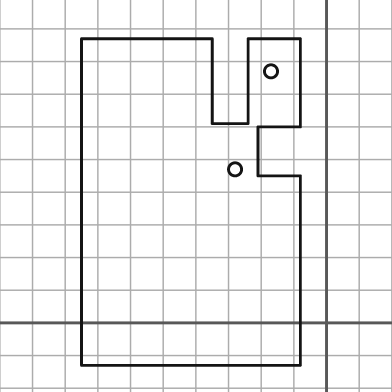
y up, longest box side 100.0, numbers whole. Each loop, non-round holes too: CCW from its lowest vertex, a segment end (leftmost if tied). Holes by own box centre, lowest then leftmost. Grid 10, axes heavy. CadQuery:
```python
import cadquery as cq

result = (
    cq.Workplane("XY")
    .moveTo(-75.0, -13.0)
    .lineTo(-8.0, -13.0)
    .lineTo(-8.0, 45.0)
    .lineTo(-21.0, 45.0)
    .lineTo(-21.0, 60.0)
    .lineTo(-8.0, 60.0)
    .lineTo(-8.0, 87.0)
    .lineTo(-24.0, 87.0)
    .lineTo(-24.0, 61.0)
    .lineTo(-35.0, 61.0)
    .lineTo(-35.0, 87.0)
    .lineTo(-75.0, 87.0)
    .close()
    .moveTo(-28.0, 47.0)
    .circle(2.0)
    .moveTo(-17.0, 77.0)
    .circle(2.0)
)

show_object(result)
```